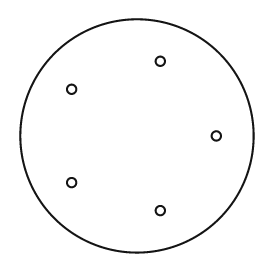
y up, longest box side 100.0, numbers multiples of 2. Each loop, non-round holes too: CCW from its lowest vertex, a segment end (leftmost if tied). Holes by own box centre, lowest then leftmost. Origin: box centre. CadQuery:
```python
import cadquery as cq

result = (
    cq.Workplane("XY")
    .moveTo(0.0, 0.0)
    .circle(50.0)
    .moveTo(10.0, -32.0)
    .circle(2.0)
    .moveTo(-28.0, -20.0)
    .circle(2.0)
    .moveTo(34.0, 0.0)
    .circle(2.0)
    .moveTo(-28.0, 20.0)
    .circle(2.0)
    .moveTo(10.0, 32.0)
    .circle(2.0)
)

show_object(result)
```